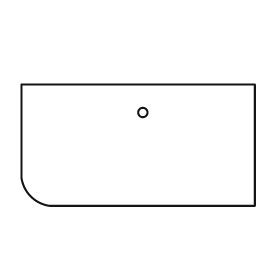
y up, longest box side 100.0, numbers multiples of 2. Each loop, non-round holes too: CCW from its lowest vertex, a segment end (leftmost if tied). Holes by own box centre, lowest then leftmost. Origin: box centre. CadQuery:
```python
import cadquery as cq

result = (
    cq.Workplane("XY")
    .moveTo(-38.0, -26.0)
    .lineTo(50.0, -26.0)
    .lineTo(50.0, 26.0)
    .lineTo(-50.0, 26.0)
    .lineTo(-50.0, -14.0)
    .threePointArc((-46.0, -22.0), (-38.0, -26.0))
    .close()
    .moveTo(2.0, 14.0)
    .circle(2.0)
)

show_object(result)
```